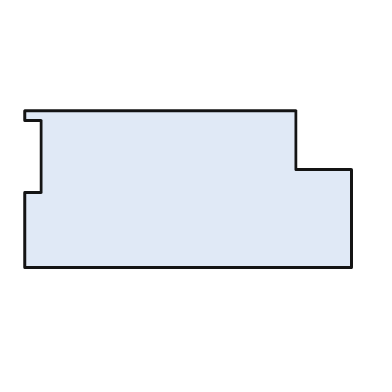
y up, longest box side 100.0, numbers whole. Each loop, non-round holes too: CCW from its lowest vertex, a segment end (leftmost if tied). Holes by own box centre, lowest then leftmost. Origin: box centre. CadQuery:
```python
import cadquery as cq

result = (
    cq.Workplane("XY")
    .moveTo(-50.0, -24.0)
    .lineTo(50.0, -24.0)
    .lineTo(50.0, 6.0)
    .lineTo(33.0, 6.0)
    .lineTo(33.0, 24.0)
    .lineTo(-50.0, 24.0)
    .lineTo(-50.0, 21.0)
    .lineTo(-45.0, 21.0)
    .lineTo(-45.0, -1.0)
    .lineTo(-50.0, -1.0)
    .close()
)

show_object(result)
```